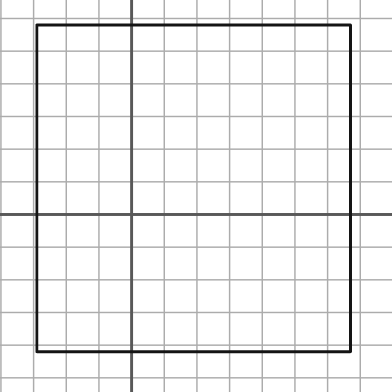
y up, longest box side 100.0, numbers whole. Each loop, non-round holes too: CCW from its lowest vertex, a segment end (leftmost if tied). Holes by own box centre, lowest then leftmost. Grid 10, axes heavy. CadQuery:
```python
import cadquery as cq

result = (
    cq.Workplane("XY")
    .moveTo(-29.0, -42.0)
    .lineTo(67.0, -42.0)
    .lineTo(67.0, 58.0)
    .lineTo(-29.0, 58.0)
    .close()
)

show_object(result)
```